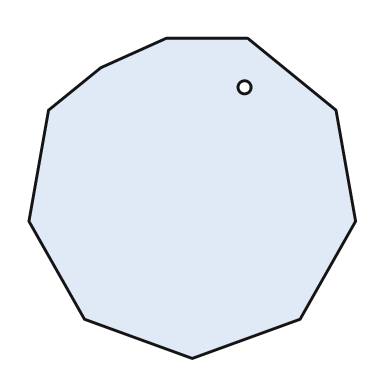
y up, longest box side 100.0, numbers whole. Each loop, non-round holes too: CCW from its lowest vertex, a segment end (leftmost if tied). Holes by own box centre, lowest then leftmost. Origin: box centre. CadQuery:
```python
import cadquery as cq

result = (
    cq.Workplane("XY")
    .moveTo(0.0, -49.0)
    .lineTo(33.0, -37.0)
    .lineTo(50.0, -7.0)
    .lineTo(44.0, 27.0)
    .lineTo(17.0, 49.0)
    .lineTo(-8.0, 49.0)
    .lineTo(-28.0, 40.0)
    .lineTo(-44.0, 27.0)
    .lineTo(-50.0, -7.0)
    .lineTo(-33.0, -37.0)
    .close()
    .moveTo(16.0, 34.0)
    .circle(2.0)
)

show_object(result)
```